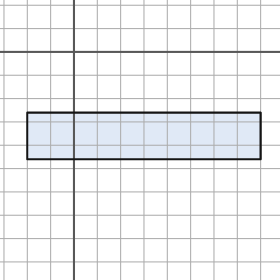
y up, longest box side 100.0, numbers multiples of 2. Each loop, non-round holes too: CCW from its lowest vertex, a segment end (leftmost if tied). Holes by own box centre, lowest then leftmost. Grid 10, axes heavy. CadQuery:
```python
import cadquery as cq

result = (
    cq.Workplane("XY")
    .moveTo(-20.0, -46.0)
    .lineTo(80.0, -46.0)
    .lineTo(80.0, -26.0)
    .lineTo(-20.0, -26.0)
    .close()
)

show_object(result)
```